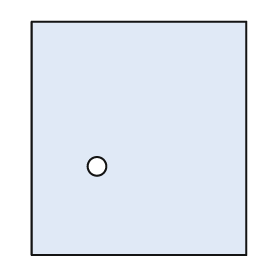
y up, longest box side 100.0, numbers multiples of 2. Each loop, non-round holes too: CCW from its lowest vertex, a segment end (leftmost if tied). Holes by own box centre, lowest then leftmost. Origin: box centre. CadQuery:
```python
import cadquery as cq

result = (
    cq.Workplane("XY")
    .moveTo(-46.0, -50.0)
    .lineTo(46.0, -50.0)
    .lineTo(46.0, 50.0)
    .lineTo(-46.0, 50.0)
    .close()
    .moveTo(-18.0, -12.0)
    .circle(4.0)
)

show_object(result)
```